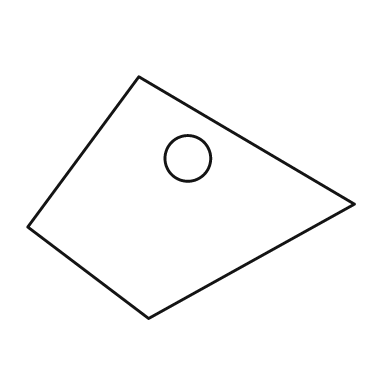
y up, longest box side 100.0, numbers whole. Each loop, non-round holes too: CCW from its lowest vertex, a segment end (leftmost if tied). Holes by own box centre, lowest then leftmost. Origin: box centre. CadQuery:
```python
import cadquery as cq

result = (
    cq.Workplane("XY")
    .moveTo(-13.0, -37.0)
    .lineTo(50.0, -2.0)
    .lineTo(-16.0, 37.0)
    .lineTo(-50.0, -9.0)
    .close()
    .moveTo(-1.0, 12.0)
    .circle(7.0)
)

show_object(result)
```